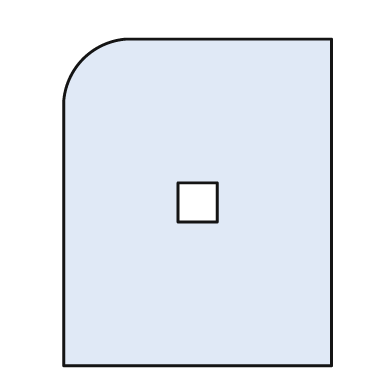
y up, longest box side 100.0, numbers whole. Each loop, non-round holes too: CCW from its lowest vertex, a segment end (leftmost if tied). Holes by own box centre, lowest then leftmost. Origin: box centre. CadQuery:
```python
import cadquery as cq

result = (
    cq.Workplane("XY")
    .moveTo(-41.0, -50.0)
    .lineTo(41.0, -50.0)
    .lineTo(41.0, 50.0)
    .lineTo(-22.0, 50.0)
    .threePointArc((-35.0, 44.0), (-41.0, 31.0))
    .close()
    .moveTo(-6.0, -6.0)
    .lineTo(6.0, -6.0)
    .lineTo(6.0, 6.0)
    .lineTo(-6.0, 6.0)
    .close()
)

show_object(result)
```